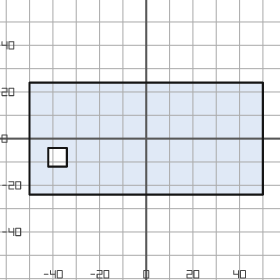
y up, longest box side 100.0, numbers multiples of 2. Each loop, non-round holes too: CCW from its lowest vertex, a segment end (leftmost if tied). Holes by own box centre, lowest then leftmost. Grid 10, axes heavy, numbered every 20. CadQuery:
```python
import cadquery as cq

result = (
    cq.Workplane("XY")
    .moveTo(-50.0, -24.0)
    .lineTo(50.0, -24.0)
    .lineTo(50.0, 24.0)
    .lineTo(-50.0, 24.0)
    .close()
    .moveTo(-42.0, -12.0)
    .lineTo(-34.0, -12.0)
    .lineTo(-34.0, -4.0)
    .lineTo(-42.0, -4.0)
    .close()
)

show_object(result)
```